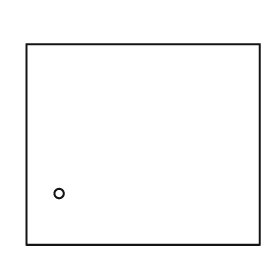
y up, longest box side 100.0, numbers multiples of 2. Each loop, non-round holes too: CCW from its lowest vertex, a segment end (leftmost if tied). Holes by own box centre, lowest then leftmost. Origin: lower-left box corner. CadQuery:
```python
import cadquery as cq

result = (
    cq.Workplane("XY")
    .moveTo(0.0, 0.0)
    .lineTo(100.0, 0.0)
    .lineTo(100.0, 86.0)
    .lineTo(0.0, 86.0)
    .close()
    .moveTo(14.0, 22.0)
    .circle(2.0)
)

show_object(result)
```